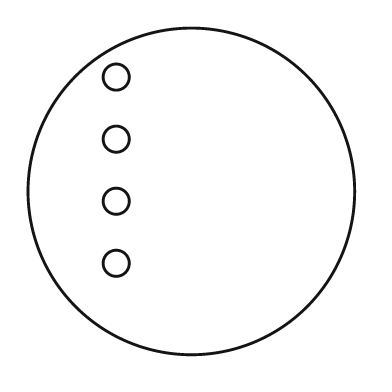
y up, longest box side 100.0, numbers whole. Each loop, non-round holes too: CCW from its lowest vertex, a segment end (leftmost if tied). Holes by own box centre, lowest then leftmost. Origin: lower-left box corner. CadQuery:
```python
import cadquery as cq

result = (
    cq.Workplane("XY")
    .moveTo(50.0, 50.0)
    .circle(50.0)
    .moveTo(27.0, 28.0)
    .circle(4.0)
    .moveTo(27.0, 47.0)
    .circle(4.0)
    .moveTo(27.0, 66.0)
    .circle(4.0)
    .moveTo(27.0, 85.0)
    .circle(4.0)
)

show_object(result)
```